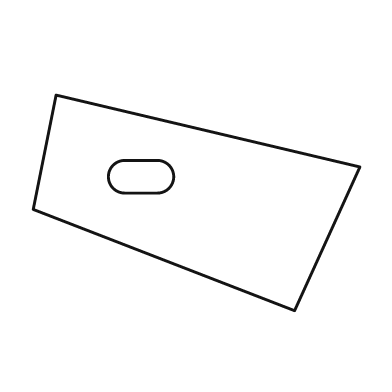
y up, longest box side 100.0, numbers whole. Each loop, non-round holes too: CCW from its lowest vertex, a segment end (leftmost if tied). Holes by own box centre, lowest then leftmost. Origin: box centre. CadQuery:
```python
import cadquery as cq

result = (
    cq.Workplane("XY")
    .moveTo(30.0, -33.0)
    .lineTo(50.0, 11.0)
    .lineTo(-43.0, 33.0)
    .lineTo(-50.0, -2.0)
    .close()
    .moveTo(-22.0, 3.0)
    .lineTo(-12.0, 3.0)
    .threePointArc((-7.0, 8.0), (-12.0, 13.0))
    .lineTo(-22.0, 13.0)
    .threePointArc((-27.0, 8.0), (-22.0, 3.0))
    .close()
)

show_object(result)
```